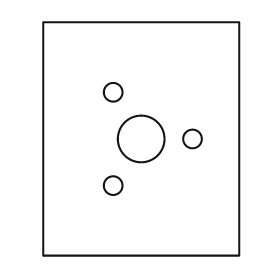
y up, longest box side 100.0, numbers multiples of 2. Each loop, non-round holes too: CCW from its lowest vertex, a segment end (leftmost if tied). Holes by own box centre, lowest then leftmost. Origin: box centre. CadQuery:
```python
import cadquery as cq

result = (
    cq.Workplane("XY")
    .moveTo(-42.0, -50.0)
    .lineTo(42.0, -50.0)
    .lineTo(42.0, 50.0)
    .lineTo(-42.0, 50.0)
    .close()
    .moveTo(-12.0, -20.0)
    .circle(4.0)
    .moveTo(0.0, 0.0)
    .circle(10.0)
    .moveTo(22.0, 0.0)
    .circle(4.0)
    .moveTo(-12.0, 20.0)
    .circle(4.0)
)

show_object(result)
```